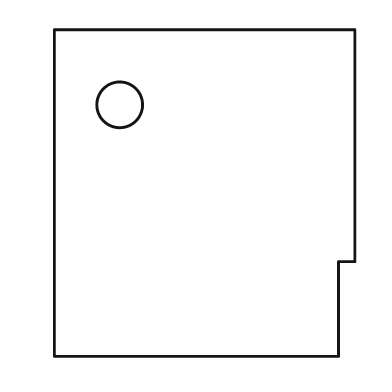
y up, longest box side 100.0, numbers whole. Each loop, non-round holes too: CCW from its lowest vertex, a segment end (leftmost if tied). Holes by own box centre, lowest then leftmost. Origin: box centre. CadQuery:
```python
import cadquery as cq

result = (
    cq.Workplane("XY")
    .moveTo(-46.0, -50.0)
    .lineTo(41.0, -50.0)
    .lineTo(41.0, -21.0)
    .lineTo(46.0, -21.0)
    .lineTo(46.0, 50.0)
    .lineTo(-46.0, 50.0)
    .close()
    .moveTo(-26.0, 27.0)
    .circle(7.0)
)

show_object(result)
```